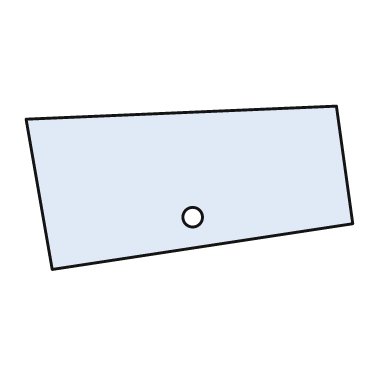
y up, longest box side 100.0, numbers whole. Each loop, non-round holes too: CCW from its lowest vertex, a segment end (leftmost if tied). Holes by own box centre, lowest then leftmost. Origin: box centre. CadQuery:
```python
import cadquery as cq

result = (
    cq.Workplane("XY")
    .moveTo(-42.0, -25.0)
    .lineTo(50.0, -11.0)
    .lineTo(45.0, 25.0)
    .lineTo(-50.0, 21.0)
    .close()
    .moveTo(1.0, -9.0)
    .circle(3.0)
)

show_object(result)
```